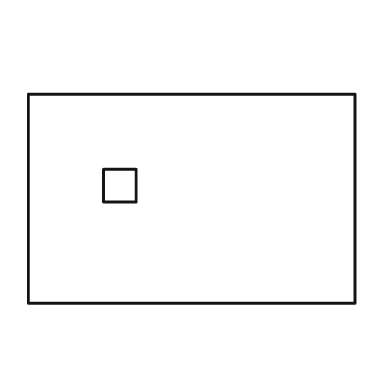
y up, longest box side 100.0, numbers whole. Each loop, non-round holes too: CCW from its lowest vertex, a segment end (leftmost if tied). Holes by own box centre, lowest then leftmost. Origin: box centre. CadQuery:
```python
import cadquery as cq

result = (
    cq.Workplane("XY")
    .moveTo(-50.0, -32.0)
    .lineTo(50.0, -32.0)
    .lineTo(50.0, 32.0)
    .lineTo(-50.0, 32.0)
    .close()
    .moveTo(-27.0, -1.0)
    .lineTo(-17.0, -1.0)
    .lineTo(-17.0, 9.0)
    .lineTo(-27.0, 9.0)
    .close()
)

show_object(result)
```